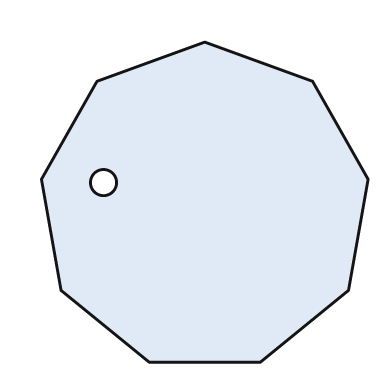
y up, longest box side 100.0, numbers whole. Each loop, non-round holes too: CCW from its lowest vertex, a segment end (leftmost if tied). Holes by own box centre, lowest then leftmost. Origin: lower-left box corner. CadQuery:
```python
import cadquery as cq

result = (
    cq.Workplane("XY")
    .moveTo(33.0, 0.0)
    .lineTo(67.0, 0.0)
    .lineTo(94.0, 22.0)
    .lineTo(100.0, 56.0)
    .lineTo(83.0, 86.0)
    .lineTo(50.0, 98.0)
    .lineTo(17.0, 86.0)
    .lineTo(0.0, 56.0)
    .lineTo(6.0, 22.0)
    .close()
    .moveTo(19.0, 55.0)
    .circle(4.0)
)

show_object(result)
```